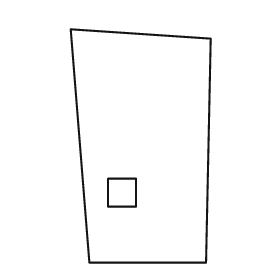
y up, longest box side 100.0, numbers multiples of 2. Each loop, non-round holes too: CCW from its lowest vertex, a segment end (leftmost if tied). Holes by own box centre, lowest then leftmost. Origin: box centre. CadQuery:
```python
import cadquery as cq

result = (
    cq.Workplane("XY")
    .moveTo(-22.0, -50.0)
    .lineTo(28.0, -50.0)
    .lineTo(30.0, 46.0)
    .lineTo(-30.0, 50.0)
    .close()
    .moveTo(-14.0, -26.0)
    .lineTo(-2.0, -26.0)
    .lineTo(-2.0, -14.0)
    .lineTo(-14.0, -14.0)
    .close()
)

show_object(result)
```